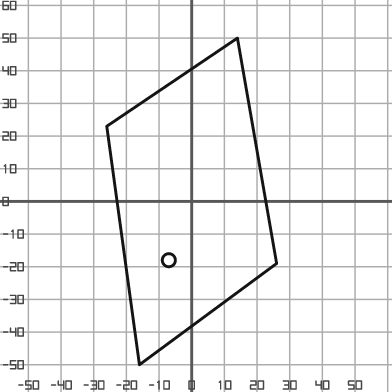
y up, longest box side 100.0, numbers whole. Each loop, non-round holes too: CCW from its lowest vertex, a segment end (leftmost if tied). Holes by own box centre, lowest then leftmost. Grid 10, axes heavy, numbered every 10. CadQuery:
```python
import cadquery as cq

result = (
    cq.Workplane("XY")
    .moveTo(-16.0, -50.0)
    .lineTo(26.0, -19.0)
    .lineTo(14.0, 50.0)
    .lineTo(-26.0, 23.0)
    .close()
    .moveTo(-7.0, -18.0)
    .circle(2.0)
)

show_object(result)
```